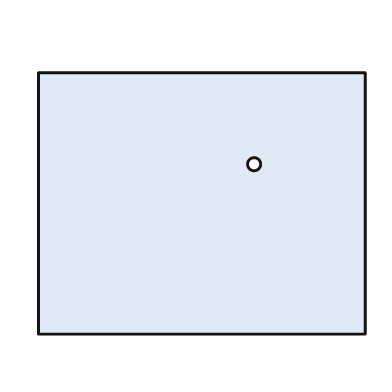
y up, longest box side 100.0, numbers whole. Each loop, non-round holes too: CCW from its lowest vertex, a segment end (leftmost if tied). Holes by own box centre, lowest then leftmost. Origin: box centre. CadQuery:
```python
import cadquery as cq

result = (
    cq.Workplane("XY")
    .moveTo(-50.0, -40.0)
    .lineTo(50.0, -40.0)
    .lineTo(50.0, 40.0)
    .lineTo(-50.0, 40.0)
    .close()
    .moveTo(16.0, 12.0)
    .circle(2.0)
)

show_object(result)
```